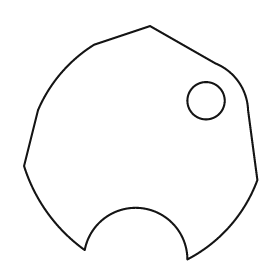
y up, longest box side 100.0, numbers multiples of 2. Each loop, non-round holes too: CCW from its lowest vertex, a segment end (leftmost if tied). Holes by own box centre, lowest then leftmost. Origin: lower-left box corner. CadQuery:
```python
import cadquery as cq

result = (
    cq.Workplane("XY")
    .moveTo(70.0, 0.0)
    .threePointArc((88.0, 14.0), (100.0, 34.0))
    .lineTo(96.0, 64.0)
    .threePointArc((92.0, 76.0), (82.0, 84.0))
    .lineTo(54.0, 100.0)
    .lineTo(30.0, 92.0)
    .threePointArc((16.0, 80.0), (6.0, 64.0))
    .lineTo(0.0, 40.0)
    .threePointArc((10.0, 20.0), (26.0, 4.0))
    .threePointArc((50.0, 22.0), (70.0, 0.0))
    .close()
    .moveTo(78.0, 68.0)
    .circle(8.0)
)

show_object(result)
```